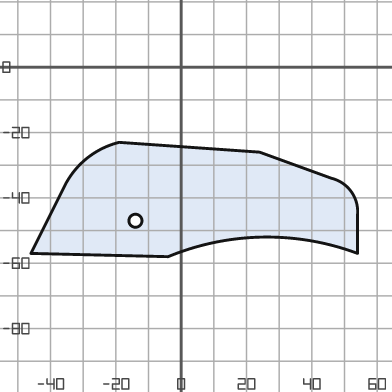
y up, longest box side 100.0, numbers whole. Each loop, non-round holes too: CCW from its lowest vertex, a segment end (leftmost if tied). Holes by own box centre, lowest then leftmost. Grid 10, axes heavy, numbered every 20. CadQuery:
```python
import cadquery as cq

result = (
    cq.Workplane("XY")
    .moveTo(-4.0, -58.0)
    .threePointArc((25.0, -52.0), (54.0, -57.0))
    .lineTo(54.0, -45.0)
    .threePointArc((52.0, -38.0), (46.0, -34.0))
    .lineTo(24.0, -26.0)
    .lineTo(-19.0, -23.0)
    .threePointArc((-29.0, -28.0), (-36.0, -37.0))
    .lineTo(-46.0, -57.0)
    .close()
    .moveTo(-14.0, -47.0)
    .circle(2.0)
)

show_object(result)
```